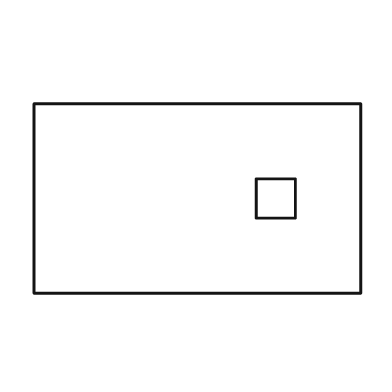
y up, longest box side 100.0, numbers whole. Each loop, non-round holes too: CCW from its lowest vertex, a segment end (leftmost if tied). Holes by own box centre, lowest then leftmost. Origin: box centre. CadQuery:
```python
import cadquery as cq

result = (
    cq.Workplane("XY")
    .moveTo(-50.0, -29.0)
    .lineTo(50.0, -29.0)
    .lineTo(50.0, 29.0)
    .lineTo(-50.0, 29.0)
    .close()
    .moveTo(18.0, -6.0)
    .lineTo(30.0, -6.0)
    .lineTo(30.0, 6.0)
    .lineTo(18.0, 6.0)
    .close()
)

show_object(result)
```